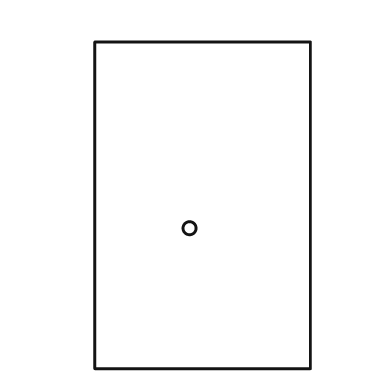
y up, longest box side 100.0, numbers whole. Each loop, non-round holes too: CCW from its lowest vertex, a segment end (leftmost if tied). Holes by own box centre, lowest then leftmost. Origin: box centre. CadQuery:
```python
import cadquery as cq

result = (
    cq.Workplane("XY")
    .moveTo(-33.0, -50.0)
    .lineTo(33.0, -50.0)
    .lineTo(33.0, 50.0)
    .lineTo(-33.0, 50.0)
    .close()
    .moveTo(-4.0, -7.0)
    .circle(2.0)
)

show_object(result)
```